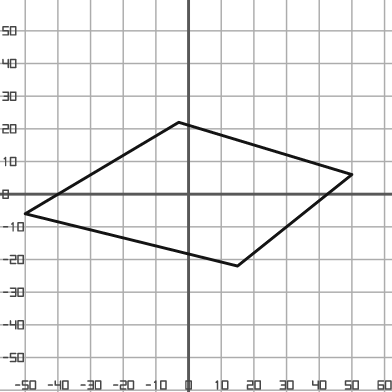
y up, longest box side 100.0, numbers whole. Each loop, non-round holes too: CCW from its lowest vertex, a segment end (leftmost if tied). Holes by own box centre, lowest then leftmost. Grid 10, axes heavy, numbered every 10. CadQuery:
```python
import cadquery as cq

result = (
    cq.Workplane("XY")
    .moveTo(15.0, -22.0)
    .lineTo(50.0, 6.0)
    .lineTo(-3.0, 22.0)
    .lineTo(-50.0, -6.0)
    .close()
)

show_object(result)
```